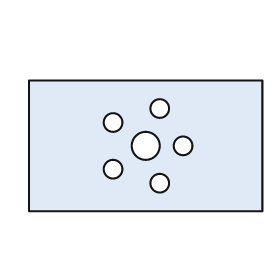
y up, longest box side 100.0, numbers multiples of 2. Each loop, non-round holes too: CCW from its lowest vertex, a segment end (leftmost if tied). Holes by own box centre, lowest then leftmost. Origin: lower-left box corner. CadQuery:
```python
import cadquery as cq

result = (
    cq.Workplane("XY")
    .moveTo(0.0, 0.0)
    .lineTo(100.0, 0.0)
    .lineTo(100.0, 56.0)
    .lineTo(0.0, 56.0)
    .close()
    .moveTo(56.0, 12.0)
    .circle(4.0)
    .moveTo(36.0, 18.0)
    .circle(4.0)
    .moveTo(50.0, 28.0)
    .circle(6.0)
    .moveTo(66.0, 28.0)
    .circle(4.0)
    .moveTo(36.0, 38.0)
    .circle(4.0)
    .moveTo(56.0, 44.0)
    .circle(4.0)
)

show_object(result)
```